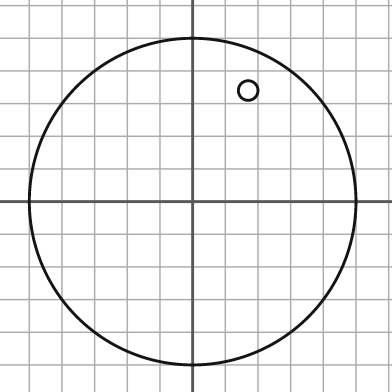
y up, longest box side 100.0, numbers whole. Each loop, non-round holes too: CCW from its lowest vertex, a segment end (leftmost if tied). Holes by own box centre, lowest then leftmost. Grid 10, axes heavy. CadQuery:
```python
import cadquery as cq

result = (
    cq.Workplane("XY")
    .moveTo(0.0, 0.0)
    .circle(50.0)
    .moveTo(17.0, 34.0)
    .circle(3.0)
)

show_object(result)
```